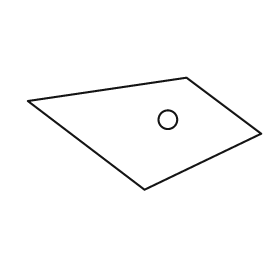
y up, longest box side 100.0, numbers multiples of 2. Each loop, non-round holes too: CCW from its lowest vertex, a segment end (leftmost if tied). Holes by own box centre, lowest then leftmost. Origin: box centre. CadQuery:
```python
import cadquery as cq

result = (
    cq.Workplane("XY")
    .moveTo(0.0, -24.0)
    .lineTo(50.0, 0.0)
    .lineTo(18.0, 24.0)
    .lineTo(-50.0, 14.0)
    .close()
    .moveTo(10.0, 6.0)
    .circle(4.0)
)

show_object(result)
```